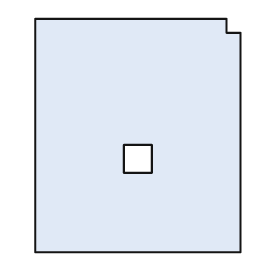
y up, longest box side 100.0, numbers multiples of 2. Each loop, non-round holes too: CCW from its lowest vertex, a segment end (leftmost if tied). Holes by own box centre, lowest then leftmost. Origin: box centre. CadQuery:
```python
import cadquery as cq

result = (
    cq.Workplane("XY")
    .moveTo(-44.0, -50.0)
    .lineTo(44.0, -50.0)
    .lineTo(44.0, 44.0)
    .lineTo(38.0, 44.0)
    .lineTo(38.0, 50.0)
    .lineTo(-44.0, 50.0)
    .close()
    .moveTo(-6.0, -16.0)
    .lineTo(6.0, -16.0)
    .lineTo(6.0, -4.0)
    .lineTo(-6.0, -4.0)
    .close()
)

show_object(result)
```